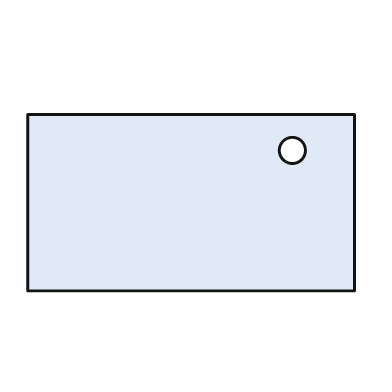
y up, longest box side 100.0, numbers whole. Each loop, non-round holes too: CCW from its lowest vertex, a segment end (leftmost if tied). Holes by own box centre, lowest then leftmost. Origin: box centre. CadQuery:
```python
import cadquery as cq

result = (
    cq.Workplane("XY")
    .moveTo(-50.0, -27.0)
    .lineTo(50.0, -27.0)
    .lineTo(50.0, 27.0)
    .lineTo(-50.0, 27.0)
    .close()
    .moveTo(31.0, 16.0)
    .circle(4.0)
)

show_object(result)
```